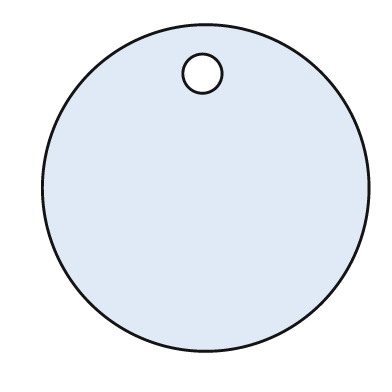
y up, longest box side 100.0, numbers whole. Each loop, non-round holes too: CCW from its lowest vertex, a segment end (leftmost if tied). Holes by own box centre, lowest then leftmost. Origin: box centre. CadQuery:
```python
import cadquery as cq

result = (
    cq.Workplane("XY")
    .moveTo(0.0, 0.0)
    .circle(50.0)
    .moveTo(-1.0, 35.0)
    .circle(6.0)
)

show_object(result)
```